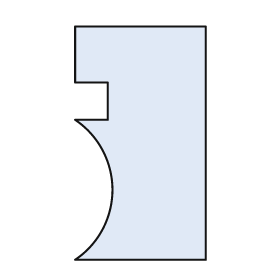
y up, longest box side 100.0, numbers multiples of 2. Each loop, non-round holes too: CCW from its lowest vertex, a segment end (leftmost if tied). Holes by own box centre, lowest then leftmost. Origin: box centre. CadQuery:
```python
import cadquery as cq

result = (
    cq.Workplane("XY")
    .moveTo(-28.0, -50.0)
    .lineTo(28.0, -50.0)
    .lineTo(28.0, 50.0)
    .lineTo(-28.0, 50.0)
    .lineTo(-28.0, 26.0)
    .lineTo(-14.0, 26.0)
    .lineTo(-14.0, 10.0)
    .lineTo(-28.0, 10.0)
    .threePointArc((-12.0, -20.0), (-28.0, -50.0))
    .close()
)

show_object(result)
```